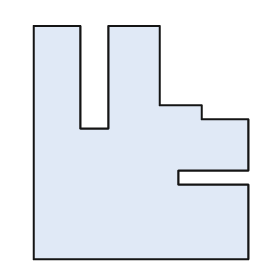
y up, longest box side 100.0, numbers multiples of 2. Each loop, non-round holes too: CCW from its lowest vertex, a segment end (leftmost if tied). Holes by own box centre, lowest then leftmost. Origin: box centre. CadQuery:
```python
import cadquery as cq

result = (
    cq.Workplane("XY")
    .moveTo(-46.0, -50.0)
    .lineTo(46.0, -50.0)
    .lineTo(46.0, -18.0)
    .lineTo(16.0, -18.0)
    .lineTo(16.0, -12.0)
    .lineTo(46.0, -12.0)
    .lineTo(46.0, 10.0)
    .lineTo(26.0, 10.0)
    .lineTo(26.0, 16.0)
    .lineTo(8.0, 16.0)
    .lineTo(8.0, 50.0)
    .lineTo(-14.0, 50.0)
    .lineTo(-14.0, 6.0)
    .lineTo(-26.0, 6.0)
    .lineTo(-26.0, 50.0)
    .lineTo(-46.0, 50.0)
    .close()
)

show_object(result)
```